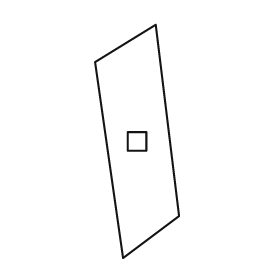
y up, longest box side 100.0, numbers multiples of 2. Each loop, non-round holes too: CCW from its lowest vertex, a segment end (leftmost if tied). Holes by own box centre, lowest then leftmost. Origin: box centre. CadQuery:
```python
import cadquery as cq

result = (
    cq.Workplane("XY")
    .moveTo(-6.0, -50.0)
    .lineTo(18.0, -32.0)
    .lineTo(8.0, 50.0)
    .lineTo(-18.0, 34.0)
    .close()
    .moveTo(-4.0, -4.0)
    .lineTo(4.0, -4.0)
    .lineTo(4.0, 4.0)
    .lineTo(-4.0, 4.0)
    .close()
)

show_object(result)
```